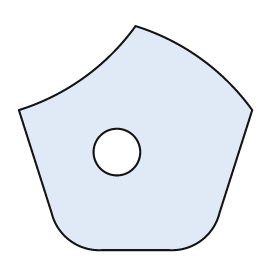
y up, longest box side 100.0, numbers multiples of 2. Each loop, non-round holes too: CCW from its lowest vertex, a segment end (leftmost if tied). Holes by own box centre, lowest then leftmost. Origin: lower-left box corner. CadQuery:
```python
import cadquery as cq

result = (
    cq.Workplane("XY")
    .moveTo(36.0, 0.0)
    .lineTo(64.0, 0.0)
    .threePointArc((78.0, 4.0), (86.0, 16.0))
    .lineTo(100.0, 60.0)
    .threePointArc((78.0, 82.0), (50.0, 96.0))
    .threePointArc((28.0, 74.0), (0.0, 60.0))
    .lineTo(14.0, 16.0)
    .threePointArc((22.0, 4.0), (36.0, 0.0))
    .close()
    .moveTo(42.0, 42.0)
    .circle(10.0)
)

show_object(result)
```